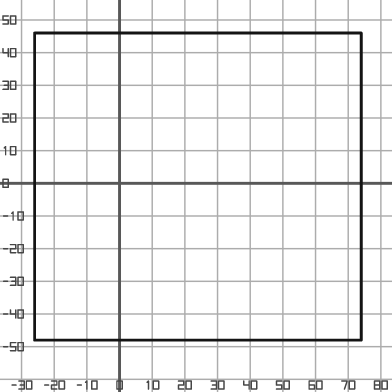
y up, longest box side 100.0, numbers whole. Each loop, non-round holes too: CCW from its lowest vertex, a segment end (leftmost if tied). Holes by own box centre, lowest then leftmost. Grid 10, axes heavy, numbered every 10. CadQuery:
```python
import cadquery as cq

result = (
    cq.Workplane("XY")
    .moveTo(-26.0, -48.0)
    .lineTo(74.0, -48.0)
    .lineTo(74.0, 46.0)
    .lineTo(-26.0, 46.0)
    .close()
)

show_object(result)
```